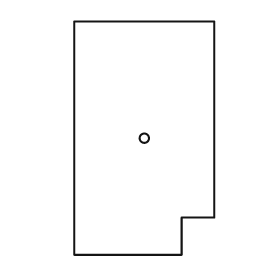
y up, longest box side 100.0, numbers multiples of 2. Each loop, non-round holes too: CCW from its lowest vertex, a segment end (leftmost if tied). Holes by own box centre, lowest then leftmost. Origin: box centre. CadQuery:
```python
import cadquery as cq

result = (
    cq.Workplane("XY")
    .moveTo(-30.0, -50.0)
    .lineTo(16.0, -50.0)
    .lineTo(16.0, -34.0)
    .lineTo(30.0, -34.0)
    .lineTo(30.0, 50.0)
    .lineTo(-30.0, 50.0)
    .close()
    .moveTo(0.0, 0.0)
    .circle(2.0)
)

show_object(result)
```